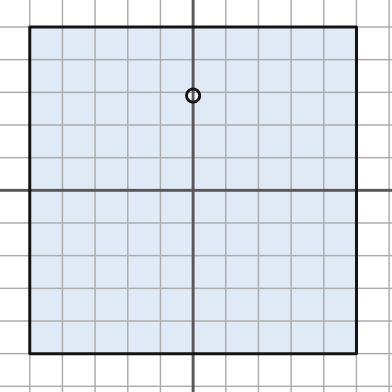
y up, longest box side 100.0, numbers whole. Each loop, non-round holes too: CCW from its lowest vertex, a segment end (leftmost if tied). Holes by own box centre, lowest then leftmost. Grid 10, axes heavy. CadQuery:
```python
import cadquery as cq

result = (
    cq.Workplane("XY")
    .moveTo(-50.0, -50.0)
    .lineTo(50.0, -50.0)
    .lineTo(50.0, 50.0)
    .lineTo(-50.0, 50.0)
    .close()
    .moveTo(0.0, 29.0)
    .circle(2.0)
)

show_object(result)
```